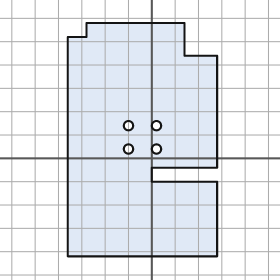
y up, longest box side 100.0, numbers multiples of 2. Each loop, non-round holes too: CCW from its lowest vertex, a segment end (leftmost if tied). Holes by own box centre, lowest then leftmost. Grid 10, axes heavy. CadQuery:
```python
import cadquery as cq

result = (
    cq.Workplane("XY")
    .moveTo(-36.0, -42.0)
    .lineTo(28.0, -42.0)
    .lineTo(28.0, -10.0)
    .lineTo(0.0, -10.0)
    .lineTo(0.0, -4.0)
    .lineTo(28.0, -4.0)
    .lineTo(28.0, 44.0)
    .lineTo(14.0, 44.0)
    .lineTo(14.0, 58.0)
    .lineTo(-28.0, 58.0)
    .lineTo(-28.0, 52.0)
    .lineTo(-36.0, 52.0)
    .close()
    .moveTo(-10.0, 4.0)
    .circle(2.0)
    .moveTo(2.0, 4.0)
    .circle(2.0)
    .moveTo(-10.0, 14.0)
    .circle(2.0)
    .moveTo(2.0, 14.0)
    .circle(2.0)
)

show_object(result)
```